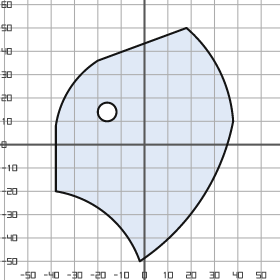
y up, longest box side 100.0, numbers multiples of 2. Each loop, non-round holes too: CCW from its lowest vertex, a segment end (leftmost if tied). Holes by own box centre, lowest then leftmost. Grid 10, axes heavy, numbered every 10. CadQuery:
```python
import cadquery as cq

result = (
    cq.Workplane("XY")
    .moveTo(-2.0, -50.0)
    .threePointArc((24.0, -24.0), (38.0, 10.0))
    .threePointArc((32.0, 32.0), (18.0, 50.0))
    .lineTo(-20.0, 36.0)
    .threePointArc((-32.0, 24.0), (-38.0, 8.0))
    .lineTo(-38.0, -20.0)
    .threePointArc((-16.0, -30.0), (-2.0, -50.0))
    .close()
    .moveTo(-16.0, 14.0)
    .circle(4.0)
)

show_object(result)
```